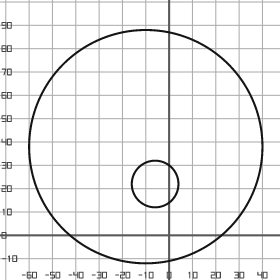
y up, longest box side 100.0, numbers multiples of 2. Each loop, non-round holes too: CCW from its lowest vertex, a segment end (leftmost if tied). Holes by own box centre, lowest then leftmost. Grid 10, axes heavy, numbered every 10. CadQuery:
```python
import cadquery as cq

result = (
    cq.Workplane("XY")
    .moveTo(-10.0, 38.0)
    .circle(50.0)
    .moveTo(-6.0, 22.0)
    .circle(10.0)
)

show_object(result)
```